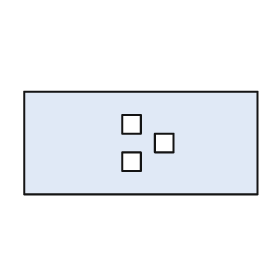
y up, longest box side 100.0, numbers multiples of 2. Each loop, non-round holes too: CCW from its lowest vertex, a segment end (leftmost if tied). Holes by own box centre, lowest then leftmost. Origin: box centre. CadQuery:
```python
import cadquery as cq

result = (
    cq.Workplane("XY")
    .moveTo(-50.0, -22.0)
    .lineTo(50.0, -22.0)
    .lineTo(50.0, 22.0)
    .lineTo(-50.0, 22.0)
    .close()
    .moveTo(-8.0, -12.0)
    .lineTo(0.0, -12.0)
    .lineTo(0.0, -4.0)
    .lineTo(-8.0, -4.0)
    .close()
    .moveTo(6.0, -4.0)
    .lineTo(14.0, -4.0)
    .lineTo(14.0, 4.0)
    .lineTo(6.0, 4.0)
    .close()
    .moveTo(-8.0, 4.0)
    .lineTo(0.0, 4.0)
    .lineTo(0.0, 12.0)
    .lineTo(-8.0, 12.0)
    .close()
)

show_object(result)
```